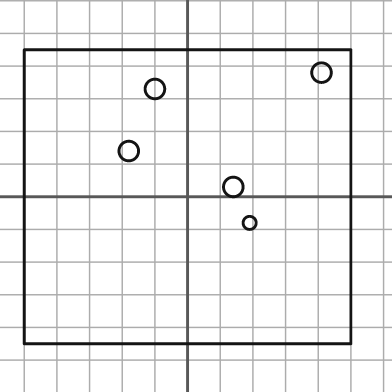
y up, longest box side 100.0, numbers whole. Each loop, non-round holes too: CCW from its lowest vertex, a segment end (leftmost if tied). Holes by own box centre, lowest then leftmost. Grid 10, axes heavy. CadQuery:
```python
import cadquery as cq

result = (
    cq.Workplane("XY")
    .moveTo(-50.0, -45.0)
    .lineTo(50.0, -45.0)
    .lineTo(50.0, 45.0)
    .lineTo(-50.0, 45.0)
    .close()
    .moveTo(19.0, -8.0)
    .circle(2.0)
    .moveTo(14.0, 3.0)
    .circle(3.0)
    .moveTo(-18.0, 14.0)
    .circle(3.0)
    .moveTo(-10.0, 33.0)
    .circle(3.0)
    .moveTo(41.0, 38.0)
    .circle(3.0)
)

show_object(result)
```